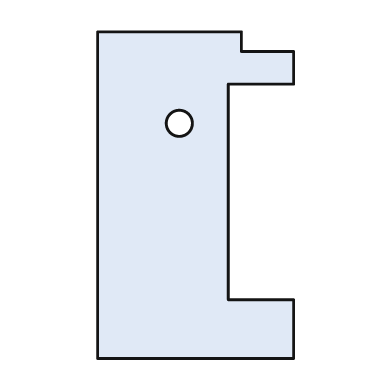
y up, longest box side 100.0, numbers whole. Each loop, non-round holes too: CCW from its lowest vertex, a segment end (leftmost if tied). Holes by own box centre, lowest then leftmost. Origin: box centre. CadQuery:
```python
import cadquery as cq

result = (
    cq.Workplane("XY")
    .moveTo(-30.0, -50.0)
    .lineTo(30.0, -50.0)
    .lineTo(30.0, -32.0)
    .lineTo(10.0, -32.0)
    .lineTo(10.0, 34.0)
    .lineTo(30.0, 34.0)
    .lineTo(30.0, 44.0)
    .lineTo(14.0, 44.0)
    .lineTo(14.0, 50.0)
    .lineTo(-30.0, 50.0)
    .close()
    .moveTo(-5.0, 22.0)
    .circle(4.0)
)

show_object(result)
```